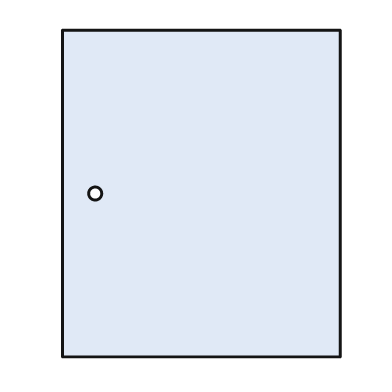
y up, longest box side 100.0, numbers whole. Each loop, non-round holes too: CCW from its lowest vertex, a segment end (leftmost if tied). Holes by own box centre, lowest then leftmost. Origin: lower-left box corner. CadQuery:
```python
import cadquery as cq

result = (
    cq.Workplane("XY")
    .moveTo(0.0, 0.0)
    .lineTo(85.0, 0.0)
    .lineTo(85.0, 100.0)
    .lineTo(0.0, 100.0)
    .close()
    .moveTo(10.0, 50.0)
    .circle(2.0)
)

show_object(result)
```